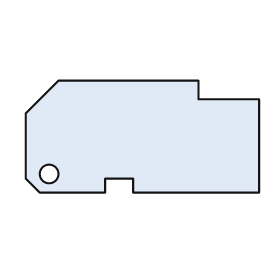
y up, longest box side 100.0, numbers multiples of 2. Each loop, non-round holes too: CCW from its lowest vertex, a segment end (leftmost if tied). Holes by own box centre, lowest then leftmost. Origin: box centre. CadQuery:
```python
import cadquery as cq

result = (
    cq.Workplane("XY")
    .moveTo(-44.0, -24.0)
    .lineTo(-16.0, -24.0)
    .lineTo(-16.0, -18.0)
    .lineTo(-4.0, -18.0)
    .lineTo(-4.0, -24.0)
    .lineTo(50.0, -24.0)
    .lineTo(50.0, 16.0)
    .lineTo(24.0, 16.0)
    .lineTo(24.0, 24.0)
    .lineTo(-36.0, 24.0)
    .lineTo(-50.0, 10.0)
    .lineTo(-50.0, -18.0)
    .close()
    .moveTo(-40.0, -16.0)
    .circle(4.0)
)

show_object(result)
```